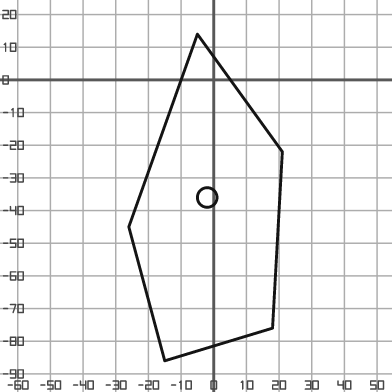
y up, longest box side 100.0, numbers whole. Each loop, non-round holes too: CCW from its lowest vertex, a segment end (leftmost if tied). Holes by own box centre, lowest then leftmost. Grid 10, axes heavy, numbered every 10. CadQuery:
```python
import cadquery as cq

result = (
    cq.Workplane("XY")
    .moveTo(-15.0, -86.0)
    .lineTo(18.0, -76.0)
    .lineTo(21.0, -22.0)
    .lineTo(-5.0, 14.0)
    .lineTo(-26.0, -45.0)
    .close()
    .moveTo(-2.0, -36.0)
    .circle(3.0)
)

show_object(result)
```